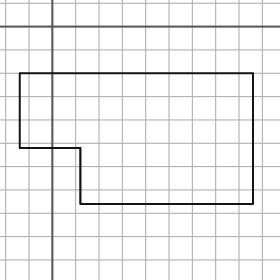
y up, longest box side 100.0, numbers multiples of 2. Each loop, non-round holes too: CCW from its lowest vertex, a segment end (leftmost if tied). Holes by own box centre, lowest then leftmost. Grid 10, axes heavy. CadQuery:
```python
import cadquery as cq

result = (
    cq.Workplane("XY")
    .moveTo(12.0, -76.0)
    .lineTo(86.0, -76.0)
    .lineTo(86.0, -20.0)
    .lineTo(-14.0, -20.0)
    .lineTo(-14.0, -52.0)
    .lineTo(12.0, -52.0)
    .close()
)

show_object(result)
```